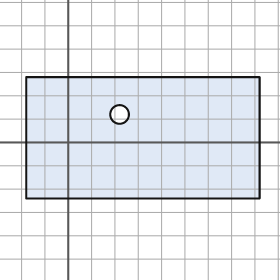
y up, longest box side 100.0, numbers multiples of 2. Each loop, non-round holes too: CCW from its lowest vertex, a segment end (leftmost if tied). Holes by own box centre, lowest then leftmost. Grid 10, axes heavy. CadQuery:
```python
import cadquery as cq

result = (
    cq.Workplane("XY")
    .moveTo(-18.0, -24.0)
    .lineTo(82.0, -24.0)
    .lineTo(82.0, 28.0)
    .lineTo(-18.0, 28.0)
    .close()
    .moveTo(22.0, 12.0)
    .circle(4.0)
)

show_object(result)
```